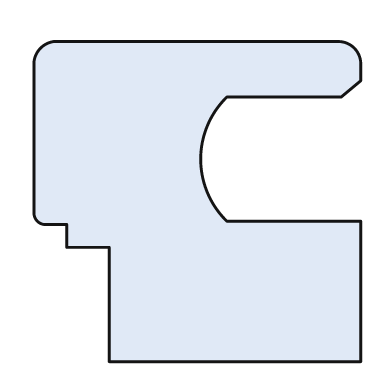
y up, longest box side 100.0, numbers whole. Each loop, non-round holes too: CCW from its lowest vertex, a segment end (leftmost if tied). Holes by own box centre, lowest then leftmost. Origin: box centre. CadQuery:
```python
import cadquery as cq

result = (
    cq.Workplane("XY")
    .moveTo(-27.0, -49.0)
    .lineTo(50.0, -49.0)
    .lineTo(50.0, -6.0)
    .lineTo(9.0, -6.0)
    .threePointArc((1.0, 13.0), (9.0, 32.0))
    .lineTo(44.0, 32.0)
    .lineTo(50.0, 37.0)
    .lineTo(50.0, 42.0)
    .threePointArc((48.0, 47.0), (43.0, 49.0))
    .lineTo(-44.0, 49.0)
    .threePointArc((-48.0, 47.0), (-50.0, 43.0))
    .lineTo(-50.0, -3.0)
    .threePointArc((-49.0, -6.0), (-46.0, -7.0))
    .lineTo(-40.0, -7.0)
    .lineTo(-40.0, -14.0)
    .lineTo(-27.0, -14.0)
    .close()
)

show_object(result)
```